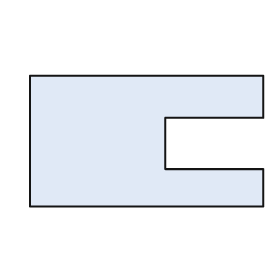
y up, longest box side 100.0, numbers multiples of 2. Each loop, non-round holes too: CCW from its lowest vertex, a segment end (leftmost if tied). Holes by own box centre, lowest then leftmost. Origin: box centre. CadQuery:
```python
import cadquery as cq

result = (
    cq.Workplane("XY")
    .moveTo(-50.0, -28.0)
    .lineTo(50.0, -28.0)
    .lineTo(50.0, -12.0)
    .lineTo(8.0, -12.0)
    .lineTo(8.0, 10.0)
    .lineTo(50.0, 10.0)
    .lineTo(50.0, 28.0)
    .lineTo(-50.0, 28.0)
    .close()
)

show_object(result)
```